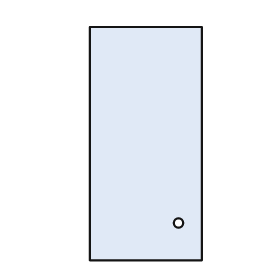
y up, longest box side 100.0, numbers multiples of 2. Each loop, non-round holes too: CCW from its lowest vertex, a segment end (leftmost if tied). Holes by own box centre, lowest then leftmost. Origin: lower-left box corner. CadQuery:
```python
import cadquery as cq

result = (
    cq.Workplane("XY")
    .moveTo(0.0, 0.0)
    .lineTo(48.0, 0.0)
    .lineTo(48.0, 100.0)
    .lineTo(0.0, 100.0)
    .close()
    .moveTo(38.0, 16.0)
    .circle(2.0)
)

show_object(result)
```